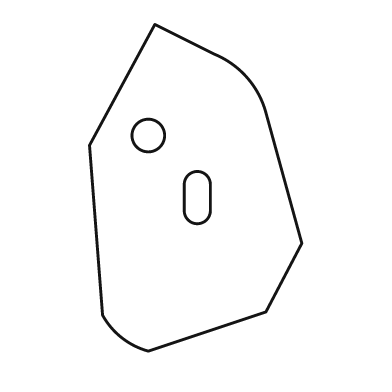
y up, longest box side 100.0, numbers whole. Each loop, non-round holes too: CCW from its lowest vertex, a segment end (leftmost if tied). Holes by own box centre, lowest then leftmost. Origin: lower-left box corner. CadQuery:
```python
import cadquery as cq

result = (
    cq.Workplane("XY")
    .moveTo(18.0, 0.0)
    .lineTo(54.0, 12.0)
    .lineTo(65.0, 33.0)
    .lineTo(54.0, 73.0)
    .threePointArc((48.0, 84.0), (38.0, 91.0))
    .lineTo(20.0, 100.0)
    .lineTo(0.0, 63.0)
    .lineTo(4.0, 11.0)
    .threePointArc((10.0, 4.0), (18.0, 0.0))
    .close()
    .moveTo(29.0, 43.0)
    .threePointArc((33.0, 39.0), (37.0, 43.0))
    .lineTo(37.0, 51.0)
    .threePointArc((33.0, 55.0), (29.0, 51.0))
    .close()
    .moveTo(18.0, 66.0)
    .circle(5.0)
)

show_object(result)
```